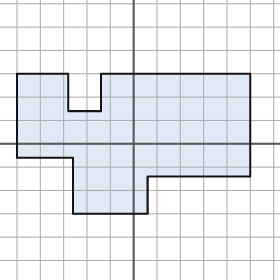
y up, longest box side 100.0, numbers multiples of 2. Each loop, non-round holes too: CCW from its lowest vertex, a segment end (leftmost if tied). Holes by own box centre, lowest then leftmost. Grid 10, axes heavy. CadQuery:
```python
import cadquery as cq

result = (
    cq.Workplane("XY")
    .moveTo(-26.0, -30.0)
    .lineTo(6.0, -30.0)
    .lineTo(6.0, -14.0)
    .lineTo(50.0, -14.0)
    .lineTo(50.0, 30.0)
    .lineTo(-14.0, 30.0)
    .lineTo(-14.0, 14.0)
    .lineTo(-28.0, 14.0)
    .lineTo(-28.0, 30.0)
    .lineTo(-50.0, 30.0)
    .lineTo(-50.0, -6.0)
    .lineTo(-26.0, -6.0)
    .close()
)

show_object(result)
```